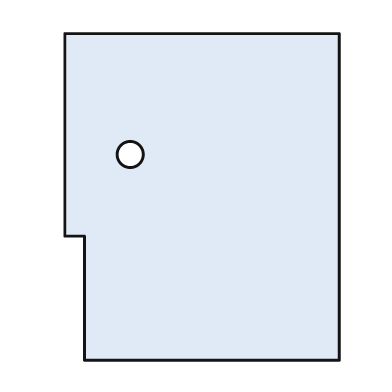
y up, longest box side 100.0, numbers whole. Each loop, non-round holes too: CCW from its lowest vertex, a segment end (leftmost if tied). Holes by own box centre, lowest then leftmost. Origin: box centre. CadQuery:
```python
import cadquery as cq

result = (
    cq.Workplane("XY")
    .moveTo(-36.0, -50.0)
    .lineTo(42.0, -50.0)
    .lineTo(42.0, 50.0)
    .lineTo(-42.0, 50.0)
    .lineTo(-42.0, -12.0)
    .lineTo(-36.0, -12.0)
    .close()
    .moveTo(-22.0, 13.0)
    .circle(4.0)
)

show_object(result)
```